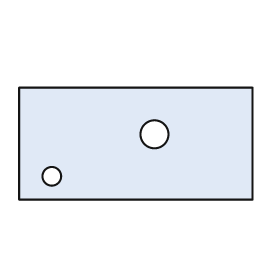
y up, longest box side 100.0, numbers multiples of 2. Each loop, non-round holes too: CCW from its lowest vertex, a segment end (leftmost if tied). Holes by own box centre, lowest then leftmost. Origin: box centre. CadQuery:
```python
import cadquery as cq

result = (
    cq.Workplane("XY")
    .moveTo(-50.0, -24.0)
    .lineTo(50.0, -24.0)
    .lineTo(50.0, 24.0)
    .lineTo(-50.0, 24.0)
    .close()
    .moveTo(-36.0, -14.0)
    .circle(4.0)
    .moveTo(8.0, 4.0)
    .circle(6.0)
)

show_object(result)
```